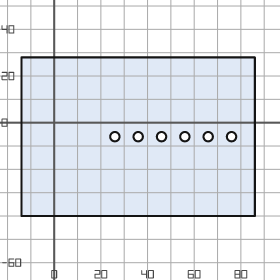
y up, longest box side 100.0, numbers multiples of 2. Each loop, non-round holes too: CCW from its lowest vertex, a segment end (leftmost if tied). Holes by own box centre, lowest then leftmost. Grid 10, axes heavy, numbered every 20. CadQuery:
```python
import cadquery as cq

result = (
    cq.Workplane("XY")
    .moveTo(-14.0, -40.0)
    .lineTo(86.0, -40.0)
    .lineTo(86.0, 28.0)
    .lineTo(-14.0, 28.0)
    .close()
    .moveTo(26.0, -6.0)
    .circle(2.0)
    .moveTo(36.0, -6.0)
    .circle(2.0)
    .moveTo(46.0, -6.0)
    .circle(2.0)
    .moveTo(56.0, -6.0)
    .circle(2.0)
    .moveTo(66.0, -6.0)
    .circle(2.0)
    .moveTo(76.0, -6.0)
    .circle(2.0)
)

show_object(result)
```